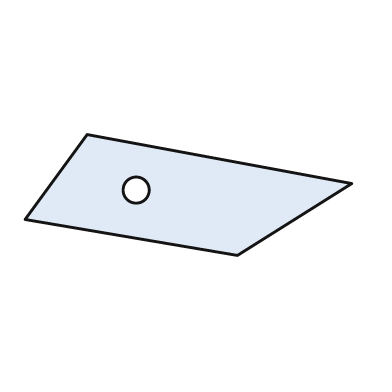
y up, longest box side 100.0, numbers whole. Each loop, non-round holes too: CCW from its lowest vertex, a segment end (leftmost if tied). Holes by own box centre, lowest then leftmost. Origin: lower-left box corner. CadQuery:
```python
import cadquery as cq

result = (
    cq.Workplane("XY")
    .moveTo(65.0, 0.0)
    .lineTo(100.0, 22.0)
    .lineTo(19.0, 37.0)
    .lineTo(0.0, 11.0)
    .close()
    .moveTo(34.0, 20.0)
    .circle(4.0)
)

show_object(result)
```